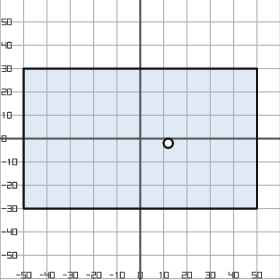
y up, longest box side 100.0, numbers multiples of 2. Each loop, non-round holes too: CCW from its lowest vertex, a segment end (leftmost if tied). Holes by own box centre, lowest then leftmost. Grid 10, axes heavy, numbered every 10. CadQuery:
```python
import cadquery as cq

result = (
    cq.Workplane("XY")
    .moveTo(-50.0, -30.0)
    .lineTo(50.0, -30.0)
    .lineTo(50.0, 30.0)
    .lineTo(-50.0, 30.0)
    .close()
    .moveTo(12.0, -2.0)
    .circle(2.0)
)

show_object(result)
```